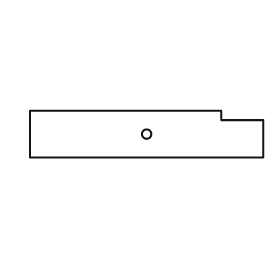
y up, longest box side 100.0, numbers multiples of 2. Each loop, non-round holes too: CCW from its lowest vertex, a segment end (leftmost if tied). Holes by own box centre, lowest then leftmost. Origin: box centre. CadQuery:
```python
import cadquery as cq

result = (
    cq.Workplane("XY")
    .moveTo(-50.0, -10.0)
    .lineTo(50.0, -10.0)
    .lineTo(50.0, 6.0)
    .lineTo(32.0, 6.0)
    .lineTo(32.0, 10.0)
    .lineTo(-50.0, 10.0)
    .close()
    .moveTo(0.0, 0.0)
    .circle(2.0)
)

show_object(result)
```